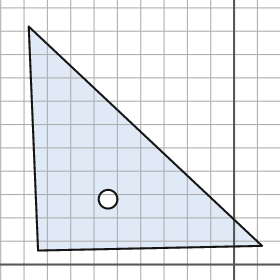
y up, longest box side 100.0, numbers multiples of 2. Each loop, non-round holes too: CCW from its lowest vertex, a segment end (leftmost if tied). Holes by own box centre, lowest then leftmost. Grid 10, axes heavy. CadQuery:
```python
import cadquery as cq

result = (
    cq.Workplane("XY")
    .moveTo(-84.0, 6.0)
    .lineTo(12.0, 8.0)
    .lineTo(-88.0, 102.0)
    .close()
    .moveTo(-54.0, 28.0)
    .circle(4.0)
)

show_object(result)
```